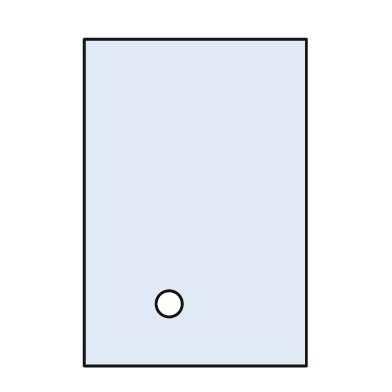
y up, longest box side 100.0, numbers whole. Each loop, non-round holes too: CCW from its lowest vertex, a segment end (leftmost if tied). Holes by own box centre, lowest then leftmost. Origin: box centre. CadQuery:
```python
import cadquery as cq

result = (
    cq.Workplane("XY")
    .moveTo(-34.0, -50.0)
    .lineTo(34.0, -50.0)
    .lineTo(34.0, 50.0)
    .lineTo(-34.0, 50.0)
    .close()
    .moveTo(-8.0, -31.0)
    .circle(4.0)
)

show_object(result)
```